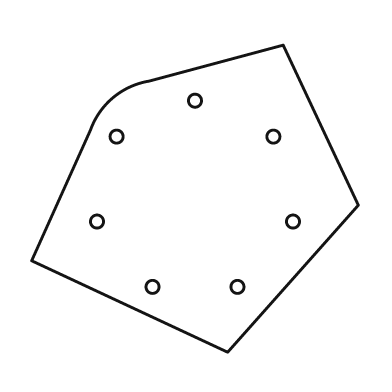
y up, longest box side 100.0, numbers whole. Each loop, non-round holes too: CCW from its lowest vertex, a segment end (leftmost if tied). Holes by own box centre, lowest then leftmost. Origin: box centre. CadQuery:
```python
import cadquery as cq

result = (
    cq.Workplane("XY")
    .moveTo(10.0, -47.0)
    .lineTo(50.0, -2.0)
    .lineTo(27.0, 47.0)
    .lineTo(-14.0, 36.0)
    .threePointArc((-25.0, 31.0), (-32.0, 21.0))
    .lineTo(-50.0, -19.0)
    .close()
    .moveTo(-13.0, -27.0)
    .circle(2.0)
    .moveTo(13.0, -27.0)
    .circle(2.0)
    .moveTo(-30.0, -7.0)
    .circle(2.0)
    .moveTo(30.0, -7.0)
    .circle(2.0)
    .moveTo(-24.0, 19.0)
    .circle(2.0)
    .moveTo(24.0, 19.0)
    .circle(2.0)
    .moveTo(0.0, 30.0)
    .circle(2.0)
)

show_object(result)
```